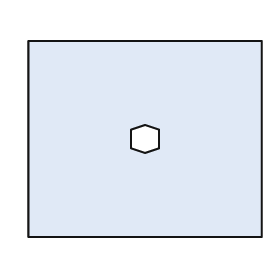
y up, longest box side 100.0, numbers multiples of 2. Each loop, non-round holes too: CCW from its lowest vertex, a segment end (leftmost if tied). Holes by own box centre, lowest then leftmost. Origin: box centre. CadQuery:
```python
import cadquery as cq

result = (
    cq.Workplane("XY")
    .moveTo(-50.0, -42.0)
    .lineTo(50.0, -42.0)
    .lineTo(50.0, 42.0)
    .lineTo(-50.0, 42.0)
    .close()
    .moveTo(0.0, -6.0)
    .lineTo(6.0, -4.0)
    .lineTo(6.0, 4.0)
    .lineTo(0.0, 6.0)
    .lineTo(-6.0, 4.0)
    .lineTo(-6.0, -4.0)
    .close()
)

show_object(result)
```